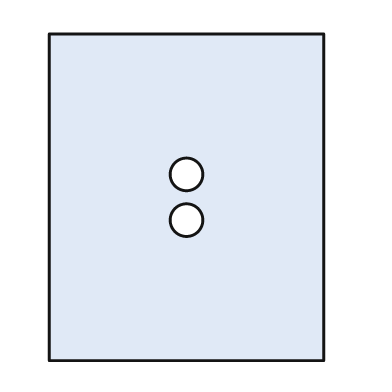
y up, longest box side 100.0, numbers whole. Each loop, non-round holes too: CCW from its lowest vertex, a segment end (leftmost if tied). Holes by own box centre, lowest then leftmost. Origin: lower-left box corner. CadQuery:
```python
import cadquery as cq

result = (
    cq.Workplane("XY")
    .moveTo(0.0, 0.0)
    .lineTo(84.0, 0.0)
    .lineTo(84.0, 100.0)
    .lineTo(0.0, 100.0)
    .close()
    .moveTo(42.0, 43.0)
    .circle(5.0)
    .moveTo(42.0, 57.0)
    .circle(5.0)
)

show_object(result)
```